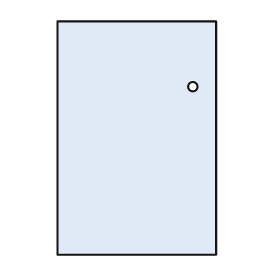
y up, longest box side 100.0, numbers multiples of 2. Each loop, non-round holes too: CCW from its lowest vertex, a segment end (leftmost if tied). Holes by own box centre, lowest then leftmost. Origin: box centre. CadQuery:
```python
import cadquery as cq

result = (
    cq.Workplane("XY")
    .moveTo(-34.0, -50.0)
    .lineTo(34.0, -50.0)
    .lineTo(34.0, 50.0)
    .lineTo(-34.0, 50.0)
    .close()
    .moveTo(24.0, 22.0)
    .circle(2.0)
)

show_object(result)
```